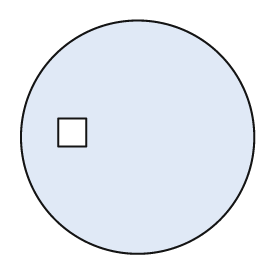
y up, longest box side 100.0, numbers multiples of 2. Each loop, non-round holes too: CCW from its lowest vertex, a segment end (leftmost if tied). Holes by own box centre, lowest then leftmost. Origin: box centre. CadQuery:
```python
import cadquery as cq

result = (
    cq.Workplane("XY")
    .moveTo(0.0, 0.0)
    .circle(50.0)
    .moveTo(-34.0, -4.0)
    .lineTo(-22.0, -4.0)
    .lineTo(-22.0, 8.0)
    .lineTo(-34.0, 8.0)
    .close()
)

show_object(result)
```